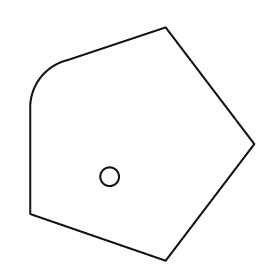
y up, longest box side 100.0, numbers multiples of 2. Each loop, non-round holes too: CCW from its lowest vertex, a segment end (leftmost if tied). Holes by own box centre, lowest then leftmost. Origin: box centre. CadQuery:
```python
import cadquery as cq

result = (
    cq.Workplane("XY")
    .moveTo(10.0, -50.0)
    .lineTo(48.0, 0.0)
    .lineTo(10.0, 50.0)
    .lineTo(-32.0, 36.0)
    .threePointArc((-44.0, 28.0), (-48.0, 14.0))
    .lineTo(-48.0, -30.0)
    .close()
    .moveTo(-14.0, -14.0)
    .circle(4.0)
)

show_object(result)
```